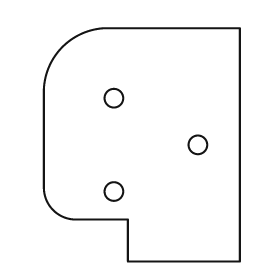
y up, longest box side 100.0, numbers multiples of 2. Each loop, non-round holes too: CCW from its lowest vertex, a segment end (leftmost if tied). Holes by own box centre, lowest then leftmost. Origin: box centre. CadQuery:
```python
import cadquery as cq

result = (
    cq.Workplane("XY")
    .moveTo(-6.0, -50.0)
    .lineTo(42.0, -50.0)
    .lineTo(42.0, 50.0)
    .lineTo(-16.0, 50.0)
    .threePointArc((-34.0, 42.0), (-42.0, 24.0))
    .lineTo(-42.0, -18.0)
    .threePointArc((-38.0, -28.0), (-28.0, -32.0))
    .lineTo(-6.0, -32.0)
    .close()
    .moveTo(-12.0, -20.0)
    .circle(4.0)
    .moveTo(24.0, 0.0)
    .circle(4.0)
    .moveTo(-12.0, 20.0)
    .circle(4.0)
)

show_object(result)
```